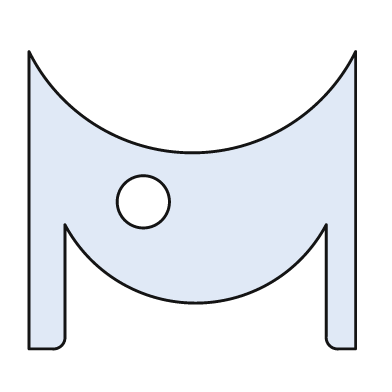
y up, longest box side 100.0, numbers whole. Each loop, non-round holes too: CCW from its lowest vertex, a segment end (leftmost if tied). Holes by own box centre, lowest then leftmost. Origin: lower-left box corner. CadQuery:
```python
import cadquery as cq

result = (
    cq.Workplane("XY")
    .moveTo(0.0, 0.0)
    .lineTo(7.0, 0.0)
    .threePointArc((10.0, 1.0), (11.0, 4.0))
    .lineTo(11.0, 38.0)
    .threePointArc((51.0, 14.0), (91.0, 38.0))
    .lineTo(91.0, 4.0)
    .threePointArc((92.0, 1.0), (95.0, 0.0))
    .lineTo(100.0, 0.0)
    .lineTo(100.0, 91.0)
    .threePointArc((50.0, 60.0), (0.0, 91.0))
    .close()
    .moveTo(35.0, 45.0)
    .circle(8.0)
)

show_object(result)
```